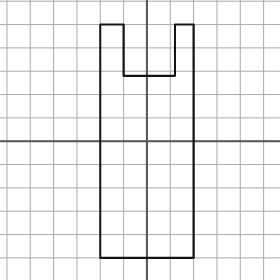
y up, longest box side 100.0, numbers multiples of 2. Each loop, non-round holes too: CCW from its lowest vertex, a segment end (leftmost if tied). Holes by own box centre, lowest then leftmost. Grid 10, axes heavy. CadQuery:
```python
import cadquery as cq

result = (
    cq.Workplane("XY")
    .moveTo(-20.0, -50.0)
    .lineTo(20.0, -50.0)
    .lineTo(20.0, 50.0)
    .lineTo(12.0, 50.0)
    .lineTo(12.0, 28.0)
    .lineTo(-10.0, 28.0)
    .lineTo(-10.0, 50.0)
    .lineTo(-20.0, 50.0)
    .close()
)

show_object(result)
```